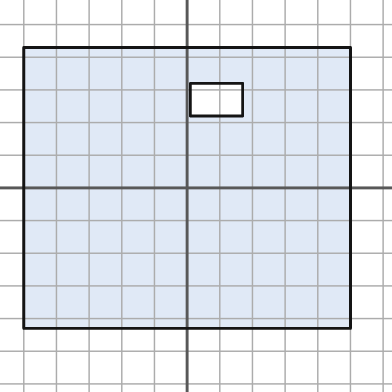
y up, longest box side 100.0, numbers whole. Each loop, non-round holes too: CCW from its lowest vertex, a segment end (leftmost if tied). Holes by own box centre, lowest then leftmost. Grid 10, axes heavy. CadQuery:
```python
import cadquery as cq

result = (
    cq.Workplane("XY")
    .moveTo(-50.0, -43.0)
    .lineTo(50.0, -43.0)
    .lineTo(50.0, 43.0)
    .lineTo(-50.0, 43.0)
    .close()
    .moveTo(1.0, 22.0)
    .lineTo(17.0, 22.0)
    .lineTo(17.0, 32.0)
    .lineTo(1.0, 32.0)
    .close()
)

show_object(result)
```